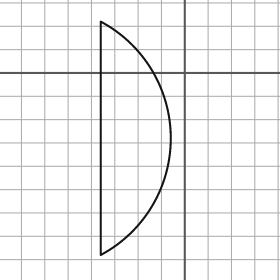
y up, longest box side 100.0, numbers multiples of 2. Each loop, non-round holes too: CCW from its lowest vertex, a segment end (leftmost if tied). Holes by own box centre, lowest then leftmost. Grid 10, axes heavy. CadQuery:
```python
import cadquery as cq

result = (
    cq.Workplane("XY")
    .moveTo(-36.0, -78.0)
    .threePointArc((-6.0, -28.0), (-36.0, 22.0))
    .close()
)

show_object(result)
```